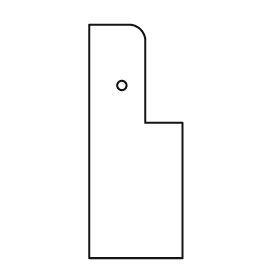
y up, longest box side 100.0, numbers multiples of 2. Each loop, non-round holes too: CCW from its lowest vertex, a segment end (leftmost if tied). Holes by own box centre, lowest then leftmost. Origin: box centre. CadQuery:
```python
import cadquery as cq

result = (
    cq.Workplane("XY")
    .moveTo(-20.0, -50.0)
    .lineTo(20.0, -50.0)
    .lineTo(20.0, 8.0)
    .lineTo(4.0, 8.0)
    .lineTo(4.0, 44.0)
    .threePointArc((2.0, 48.0), (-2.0, 50.0))
    .lineTo(-20.0, 50.0)
    .close()
    .moveTo(-6.0, 24.0)
    .circle(2.0)
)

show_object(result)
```